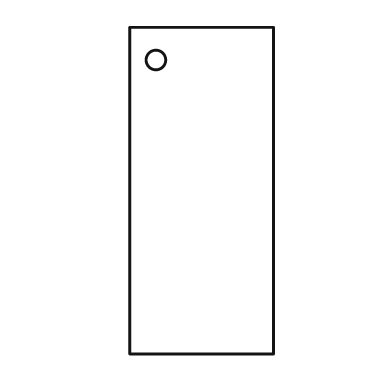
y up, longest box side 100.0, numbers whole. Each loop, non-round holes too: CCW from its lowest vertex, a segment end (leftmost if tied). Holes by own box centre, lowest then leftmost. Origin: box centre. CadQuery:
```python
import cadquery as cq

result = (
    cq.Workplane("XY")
    .moveTo(-22.0, -50.0)
    .lineTo(22.0, -50.0)
    .lineTo(22.0, 50.0)
    .lineTo(-22.0, 50.0)
    .close()
    .moveTo(-14.0, 40.0)
    .circle(3.0)
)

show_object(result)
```